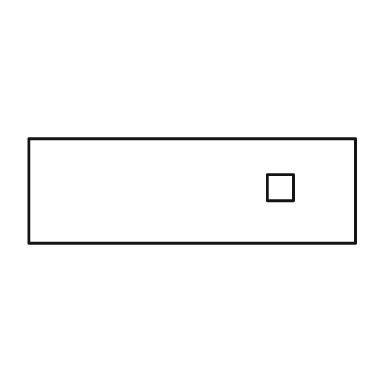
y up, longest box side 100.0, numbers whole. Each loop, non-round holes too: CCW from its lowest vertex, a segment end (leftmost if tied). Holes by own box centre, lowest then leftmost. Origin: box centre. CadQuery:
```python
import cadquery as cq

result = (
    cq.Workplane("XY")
    .moveTo(-50.0, -16.0)
    .lineTo(50.0, -16.0)
    .lineTo(50.0, 16.0)
    .lineTo(-50.0, 16.0)
    .close()
    .moveTo(23.0, -3.0)
    .lineTo(31.0, -3.0)
    .lineTo(31.0, 5.0)
    .lineTo(23.0, 5.0)
    .close()
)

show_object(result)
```